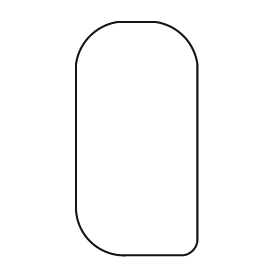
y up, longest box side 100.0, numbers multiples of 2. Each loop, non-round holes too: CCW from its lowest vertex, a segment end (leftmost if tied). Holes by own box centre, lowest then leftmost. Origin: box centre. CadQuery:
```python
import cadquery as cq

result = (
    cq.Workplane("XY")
    .moveTo(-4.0, -50.0)
    .lineTo(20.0, -50.0)
    .threePointArc((24.0, -48.0), (26.0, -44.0))
    .lineTo(26.0, 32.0)
    .threePointArc((20.0, 44.0), (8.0, 50.0))
    .lineTo(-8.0, 50.0)
    .threePointArc((-20.0, 44.0), (-26.0, 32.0))
    .lineTo(-26.0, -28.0)
    .threePointArc((-20.0, -44.0), (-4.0, -50.0))
    .close()
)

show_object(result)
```